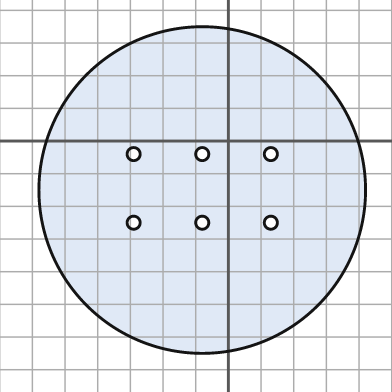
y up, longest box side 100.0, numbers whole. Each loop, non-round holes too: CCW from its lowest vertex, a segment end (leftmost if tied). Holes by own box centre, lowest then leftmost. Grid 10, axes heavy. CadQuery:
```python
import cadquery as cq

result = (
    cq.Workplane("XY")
    .moveTo(-8.0, -15.0)
    .circle(50.0)
    .moveTo(-29.0, -25.0)
    .circle(2.0)
    .moveTo(-8.0, -25.0)
    .circle(2.0)
    .moveTo(13.0, -25.0)
    .circle(2.0)
    .moveTo(-29.0, -4.0)
    .circle(2.0)
    .moveTo(-8.0, -4.0)
    .circle(2.0)
    .moveTo(13.0, -4.0)
    .circle(2.0)
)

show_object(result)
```